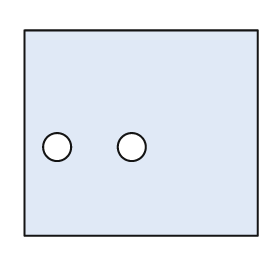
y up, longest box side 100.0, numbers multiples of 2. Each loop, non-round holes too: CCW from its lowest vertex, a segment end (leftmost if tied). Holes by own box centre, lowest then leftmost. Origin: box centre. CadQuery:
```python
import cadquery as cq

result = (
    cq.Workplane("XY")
    .moveTo(-50.0, -44.0)
    .lineTo(50.0, -44.0)
    .lineTo(50.0, 44.0)
    .lineTo(-50.0, 44.0)
    .close()
    .moveTo(-36.0, -6.0)
    .circle(6.0)
    .moveTo(-4.0, -6.0)
    .circle(6.0)
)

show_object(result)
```